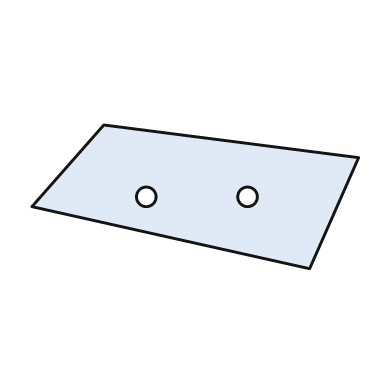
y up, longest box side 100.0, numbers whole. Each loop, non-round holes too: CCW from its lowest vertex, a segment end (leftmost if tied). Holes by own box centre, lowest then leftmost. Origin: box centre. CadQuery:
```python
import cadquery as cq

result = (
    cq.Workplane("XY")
    .moveTo(35.0, -22.0)
    .lineTo(50.0, 12.0)
    .lineTo(-28.0, 22.0)
    .lineTo(-50.0, -3.0)
    .close()
    .moveTo(-15.0, 0.0)
    .circle(3.0)
    .moveTo(16.0, 0.0)
    .circle(3.0)
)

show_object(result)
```